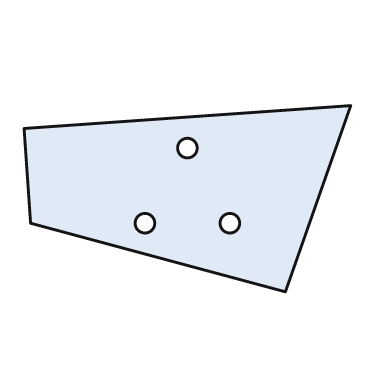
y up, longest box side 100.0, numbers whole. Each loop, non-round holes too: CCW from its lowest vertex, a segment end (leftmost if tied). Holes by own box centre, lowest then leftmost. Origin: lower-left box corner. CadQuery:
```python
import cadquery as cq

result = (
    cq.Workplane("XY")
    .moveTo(80.0, 0.0)
    .lineTo(100.0, 57.0)
    .lineTo(0.0, 50.0)
    .lineTo(2.0, 21.0)
    .close()
    .moveTo(37.0, 21.0)
    .circle(3.0)
    .moveTo(63.0, 21.0)
    .circle(3.0)
    .moveTo(50.0, 44.0)
    .circle(3.0)
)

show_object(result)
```